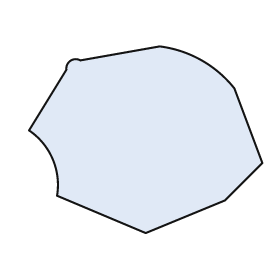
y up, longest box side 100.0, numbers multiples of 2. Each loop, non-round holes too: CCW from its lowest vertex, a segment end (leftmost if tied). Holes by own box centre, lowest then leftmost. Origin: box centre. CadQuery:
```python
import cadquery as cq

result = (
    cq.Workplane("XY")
    .moveTo(0.0, -40.0)
    .lineTo(34.0, -26.0)
    .lineTo(50.0, -10.0)
    .lineTo(38.0, 22.0)
    .threePointArc((24.0, 34.0), (6.0, 40.0))
    .lineTo(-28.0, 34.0)
    .threePointArc((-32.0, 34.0), (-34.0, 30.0))
    .lineTo(-50.0, 4.0)
    .threePointArc((-40.0, -8.0), (-38.0, -24.0))
    .close()
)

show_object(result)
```